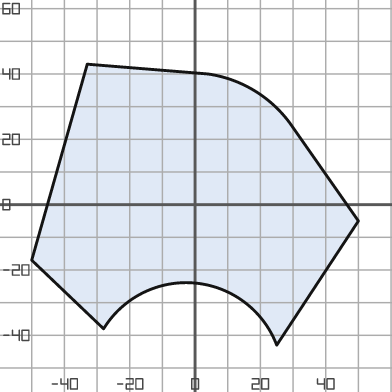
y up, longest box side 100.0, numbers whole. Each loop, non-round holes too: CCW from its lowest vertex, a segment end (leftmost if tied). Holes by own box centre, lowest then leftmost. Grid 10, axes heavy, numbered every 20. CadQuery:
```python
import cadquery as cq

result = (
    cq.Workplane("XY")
    .moveTo(25.0, -43.0)
    .lineTo(50.0, -5.0)
    .lineTo(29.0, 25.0)
    .threePointArc((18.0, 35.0), (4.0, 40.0))
    .lineTo(-33.0, 43.0)
    .lineTo(-50.0, -17.0)
    .lineTo(-28.0, -38.0)
    .threePointArc((0.0, -24.0), (25.0, -43.0))
    .close()
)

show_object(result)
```